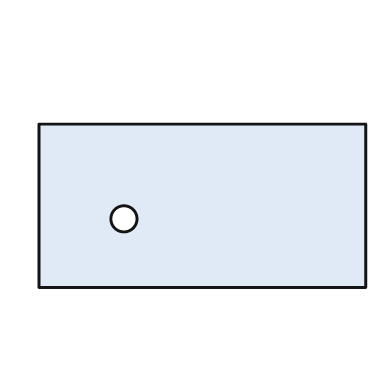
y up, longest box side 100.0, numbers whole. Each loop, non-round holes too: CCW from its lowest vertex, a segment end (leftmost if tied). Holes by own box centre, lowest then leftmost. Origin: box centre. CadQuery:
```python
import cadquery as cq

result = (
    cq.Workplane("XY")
    .moveTo(-50.0, -25.0)
    .lineTo(50.0, -25.0)
    .lineTo(50.0, 25.0)
    .lineTo(-50.0, 25.0)
    .close()
    .moveTo(-24.0, -4.0)
    .circle(4.0)
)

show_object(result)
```